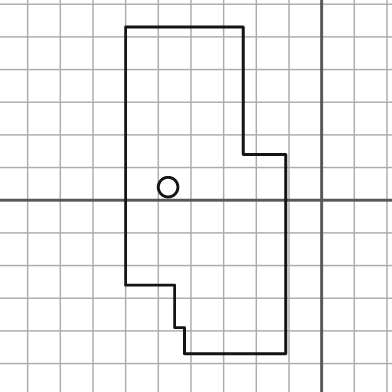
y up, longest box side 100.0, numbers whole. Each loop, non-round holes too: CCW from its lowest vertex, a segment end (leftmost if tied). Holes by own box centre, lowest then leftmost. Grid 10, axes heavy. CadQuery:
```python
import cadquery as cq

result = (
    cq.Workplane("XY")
    .moveTo(-42.0, -47.0)
    .lineTo(-11.0, -47.0)
    .lineTo(-11.0, 14.0)
    .lineTo(-24.0, 14.0)
    .lineTo(-24.0, 53.0)
    .lineTo(-60.0, 53.0)
    .lineTo(-60.0, -26.0)
    .lineTo(-45.0, -26.0)
    .lineTo(-45.0, -39.0)
    .lineTo(-42.0, -39.0)
    .close()
    .moveTo(-47.0, 4.0)
    .circle(3.0)
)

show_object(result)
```